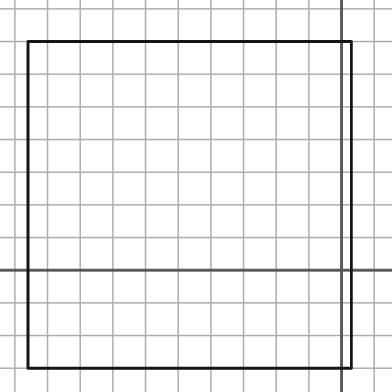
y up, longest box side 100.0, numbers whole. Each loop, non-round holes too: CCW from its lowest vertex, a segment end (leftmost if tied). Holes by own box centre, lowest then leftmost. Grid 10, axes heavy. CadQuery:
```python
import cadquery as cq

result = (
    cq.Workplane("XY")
    .moveTo(-96.0, -30.0)
    .lineTo(3.0, -30.0)
    .lineTo(3.0, 70.0)
    .lineTo(-96.0, 70.0)
    .close()
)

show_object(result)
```